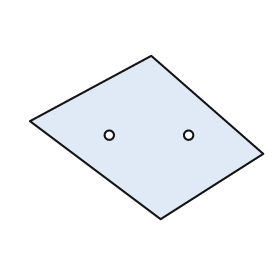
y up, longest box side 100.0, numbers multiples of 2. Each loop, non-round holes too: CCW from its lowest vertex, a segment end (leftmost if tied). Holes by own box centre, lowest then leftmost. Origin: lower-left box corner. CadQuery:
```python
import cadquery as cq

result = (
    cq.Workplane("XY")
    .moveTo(56.0, 0.0)
    .lineTo(100.0, 28.0)
    .lineTo(52.0, 70.0)
    .lineTo(0.0, 42.0)
    .close()
    .moveTo(34.0, 36.0)
    .circle(2.0)
    .moveTo(68.0, 36.0)
    .circle(2.0)
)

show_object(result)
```